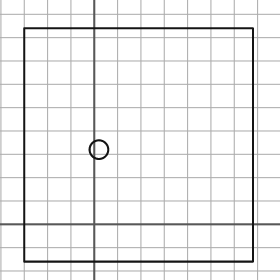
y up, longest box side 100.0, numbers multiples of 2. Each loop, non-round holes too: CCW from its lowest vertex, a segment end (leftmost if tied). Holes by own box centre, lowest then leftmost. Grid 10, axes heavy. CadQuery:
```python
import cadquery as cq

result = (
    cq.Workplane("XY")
    .moveTo(-30.0, -16.0)
    .lineTo(68.0, -16.0)
    .lineTo(68.0, 84.0)
    .lineTo(-30.0, 84.0)
    .close()
    .moveTo(2.0, 32.0)
    .circle(4.0)
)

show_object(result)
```